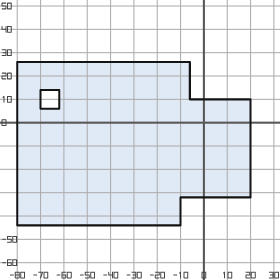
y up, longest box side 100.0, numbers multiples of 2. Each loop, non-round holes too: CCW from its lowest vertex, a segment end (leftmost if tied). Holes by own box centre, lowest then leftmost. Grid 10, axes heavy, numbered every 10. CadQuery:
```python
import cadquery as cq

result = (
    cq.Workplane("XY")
    .moveTo(-80.0, -44.0)
    .lineTo(-10.0, -44.0)
    .lineTo(-10.0, -32.0)
    .lineTo(20.0, -32.0)
    .lineTo(20.0, 10.0)
    .lineTo(-6.0, 10.0)
    .lineTo(-6.0, 26.0)
    .lineTo(-80.0, 26.0)
    .close()
    .moveTo(-70.0, 6.0)
    .lineTo(-62.0, 6.0)
    .lineTo(-62.0, 14.0)
    .lineTo(-70.0, 14.0)
    .close()
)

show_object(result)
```